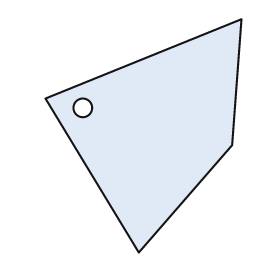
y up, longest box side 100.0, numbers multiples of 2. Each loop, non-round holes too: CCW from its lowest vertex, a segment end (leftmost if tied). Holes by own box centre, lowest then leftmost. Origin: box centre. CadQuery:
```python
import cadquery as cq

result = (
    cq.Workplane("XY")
    .moveTo(-2.0, -50.0)
    .lineTo(38.0, -4.0)
    .lineTo(42.0, 50.0)
    .lineTo(-42.0, 16.0)
    .close()
    .moveTo(-26.0, 12.0)
    .circle(4.0)
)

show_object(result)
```